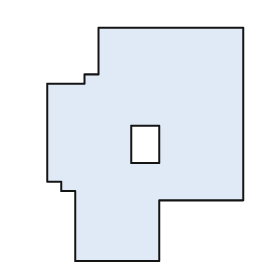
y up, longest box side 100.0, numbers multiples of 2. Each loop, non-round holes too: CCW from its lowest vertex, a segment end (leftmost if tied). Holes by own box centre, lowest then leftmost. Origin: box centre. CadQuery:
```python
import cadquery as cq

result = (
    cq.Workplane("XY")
    .moveTo(-30.0, -50.0)
    .lineTo(6.0, -50.0)
    .lineTo(6.0, -24.0)
    .lineTo(42.0, -24.0)
    .lineTo(42.0, 50.0)
    .lineTo(-20.0, 50.0)
    .lineTo(-20.0, 30.0)
    .lineTo(-26.0, 30.0)
    .lineTo(-26.0, 26.0)
    .lineTo(-42.0, 26.0)
    .lineTo(-42.0, -16.0)
    .lineTo(-36.0, -16.0)
    .lineTo(-36.0, -20.0)
    .lineTo(-30.0, -20.0)
    .close()
    .moveTo(-6.0, -8.0)
    .lineTo(6.0, -8.0)
    .lineTo(6.0, 8.0)
    .lineTo(-6.0, 8.0)
    .close()
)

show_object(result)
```